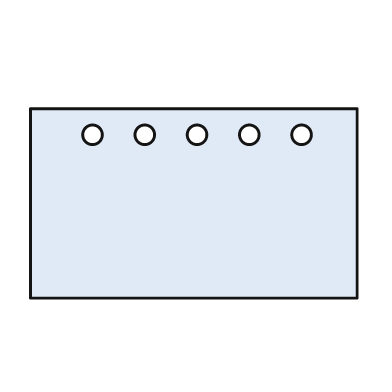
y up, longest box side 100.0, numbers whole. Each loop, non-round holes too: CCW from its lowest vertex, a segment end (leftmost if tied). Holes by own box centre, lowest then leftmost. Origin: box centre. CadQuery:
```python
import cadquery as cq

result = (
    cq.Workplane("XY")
    .moveTo(-50.0, -29.0)
    .lineTo(50.0, -29.0)
    .lineTo(50.0, 29.0)
    .lineTo(-50.0, 29.0)
    .close()
    .moveTo(-31.0, 21.0)
    .circle(3.0)
    .moveTo(-15.0, 21.0)
    .circle(3.0)
    .moveTo(1.0, 21.0)
    .circle(3.0)
    .moveTo(17.0, 21.0)
    .circle(3.0)
    .moveTo(33.0, 21.0)
    .circle(3.0)
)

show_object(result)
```